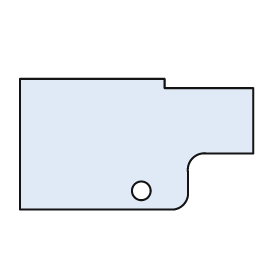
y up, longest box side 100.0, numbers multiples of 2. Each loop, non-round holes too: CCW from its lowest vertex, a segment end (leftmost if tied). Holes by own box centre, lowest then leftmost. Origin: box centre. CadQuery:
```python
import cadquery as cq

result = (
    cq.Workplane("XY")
    .moveTo(-50.0, -28.0)
    .lineTo(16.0, -28.0)
    .threePointArc((20.0, -26.0), (22.0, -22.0))
    .lineTo(22.0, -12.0)
    .threePointArc((24.0, -6.0), (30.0, -4.0))
    .lineTo(50.0, -4.0)
    .lineTo(50.0, 24.0)
    .lineTo(12.0, 24.0)
    .lineTo(12.0, 28.0)
    .lineTo(-50.0, 28.0)
    .close()
    .moveTo(2.0, -20.0)
    .circle(4.0)
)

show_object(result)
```